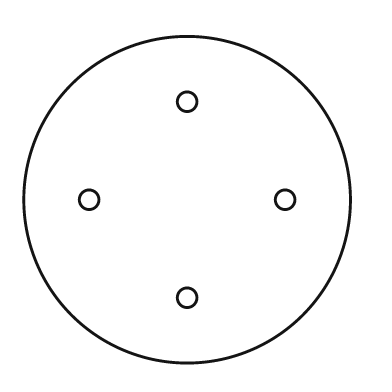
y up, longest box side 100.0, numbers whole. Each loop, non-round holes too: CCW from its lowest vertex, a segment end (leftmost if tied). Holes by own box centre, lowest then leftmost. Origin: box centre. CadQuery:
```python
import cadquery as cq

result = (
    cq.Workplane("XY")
    .moveTo(0.0, 0.0)
    .circle(50.0)
    .moveTo(0.0, -30.0)
    .circle(3.0)
    .moveTo(-30.0, 0.0)
    .circle(3.0)
    .moveTo(30.0, 0.0)
    .circle(3.0)
    .moveTo(0.0, 30.0)
    .circle(3.0)
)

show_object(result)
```